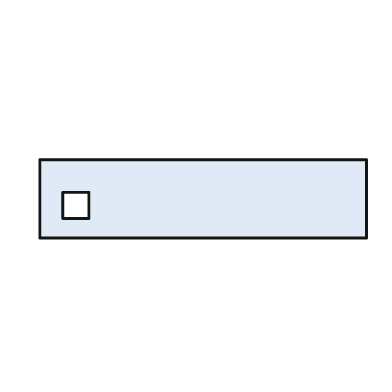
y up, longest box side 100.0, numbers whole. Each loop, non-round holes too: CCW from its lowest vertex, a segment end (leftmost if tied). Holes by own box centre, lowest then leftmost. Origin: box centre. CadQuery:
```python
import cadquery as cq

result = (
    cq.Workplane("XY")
    .moveTo(-50.0, -12.0)
    .lineTo(50.0, -12.0)
    .lineTo(50.0, 12.0)
    .lineTo(-50.0, 12.0)
    .close()
    .moveTo(-43.0, -6.0)
    .lineTo(-35.0, -6.0)
    .lineTo(-35.0, 2.0)
    .lineTo(-43.0, 2.0)
    .close()
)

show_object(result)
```